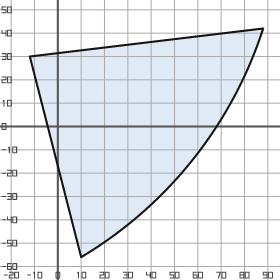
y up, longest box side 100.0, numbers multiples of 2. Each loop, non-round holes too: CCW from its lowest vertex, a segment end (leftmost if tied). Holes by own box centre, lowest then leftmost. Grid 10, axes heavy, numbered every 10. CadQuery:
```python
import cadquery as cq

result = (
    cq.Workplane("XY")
    .moveTo(10.0, -56.0)
    .threePointArc((58.0, -14.0), (88.0, 42.0))
    .lineTo(-12.0, 30.0)
    .close()
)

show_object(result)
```